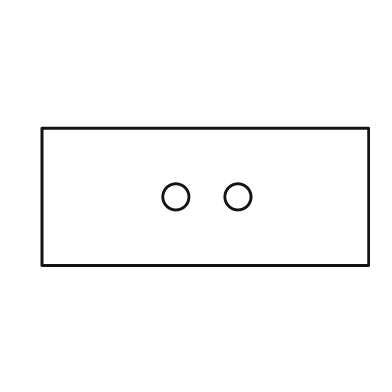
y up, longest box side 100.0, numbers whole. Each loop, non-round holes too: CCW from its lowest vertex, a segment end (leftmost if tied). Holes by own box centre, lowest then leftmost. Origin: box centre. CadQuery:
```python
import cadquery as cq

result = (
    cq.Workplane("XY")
    .moveTo(-50.0, -21.0)
    .lineTo(50.0, -21.0)
    .lineTo(50.0, 21.0)
    .lineTo(-50.0, 21.0)
    .close()
    .moveTo(-9.0, 0.0)
    .circle(4.0)
    .moveTo(10.0, 0.0)
    .circle(4.0)
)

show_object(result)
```